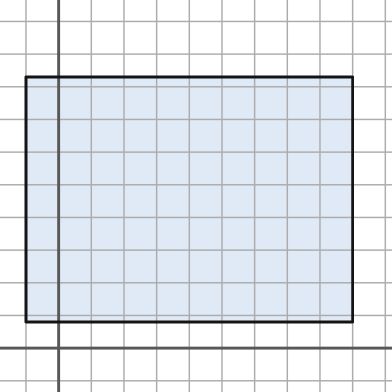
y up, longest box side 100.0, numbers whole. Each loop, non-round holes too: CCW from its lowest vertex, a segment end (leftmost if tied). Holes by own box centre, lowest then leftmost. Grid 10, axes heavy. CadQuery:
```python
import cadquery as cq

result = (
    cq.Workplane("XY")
    .moveTo(-10.0, 8.0)
    .lineTo(90.0, 8.0)
    .lineTo(90.0, 83.0)
    .lineTo(-10.0, 83.0)
    .close()
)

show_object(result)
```